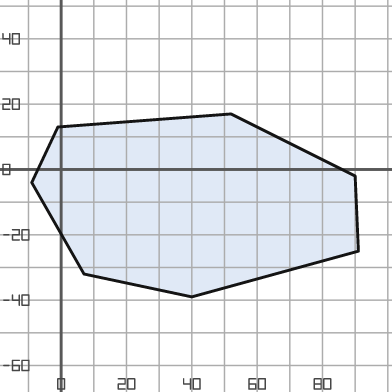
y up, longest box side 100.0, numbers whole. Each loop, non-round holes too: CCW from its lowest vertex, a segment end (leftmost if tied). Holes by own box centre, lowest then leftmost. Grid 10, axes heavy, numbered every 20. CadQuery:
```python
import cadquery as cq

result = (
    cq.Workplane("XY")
    .moveTo(40.0, -39.0)
    .lineTo(91.0, -25.0)
    .lineTo(90.0, -2.0)
    .lineTo(52.0, 17.0)
    .lineTo(-1.0, 13.0)
    .lineTo(-9.0, -4.0)
    .lineTo(7.0, -32.0)
    .close()
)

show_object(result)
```